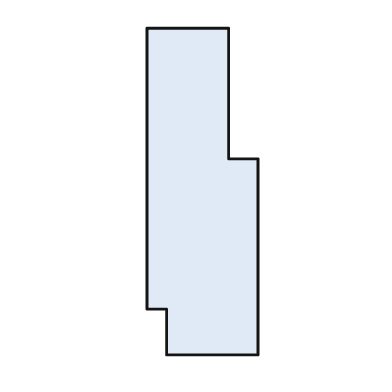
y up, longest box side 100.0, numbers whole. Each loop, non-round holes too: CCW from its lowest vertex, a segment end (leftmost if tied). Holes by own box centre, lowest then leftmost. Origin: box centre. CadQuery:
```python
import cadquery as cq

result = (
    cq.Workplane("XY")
    .moveTo(-11.0, -50.0)
    .lineTo(17.0, -50.0)
    .lineTo(17.0, 10.0)
    .lineTo(8.0, 10.0)
    .lineTo(8.0, 50.0)
    .lineTo(-17.0, 50.0)
    .lineTo(-17.0, -36.0)
    .lineTo(-11.0, -36.0)
    .close()
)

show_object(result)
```